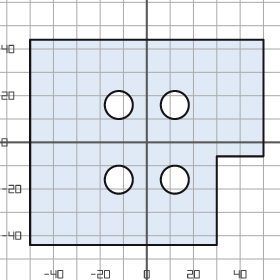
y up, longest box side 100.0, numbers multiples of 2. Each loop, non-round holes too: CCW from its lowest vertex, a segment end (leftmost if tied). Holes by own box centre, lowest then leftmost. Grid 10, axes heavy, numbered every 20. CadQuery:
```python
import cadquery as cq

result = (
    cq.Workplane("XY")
    .moveTo(-50.0, -44.0)
    .lineTo(30.0, -44.0)
    .lineTo(30.0, -6.0)
    .lineTo(50.0, -6.0)
    .lineTo(50.0, 44.0)
    .lineTo(-50.0, 44.0)
    .close()
    .moveTo(-12.0, -16.0)
    .circle(6.0)
    .moveTo(12.0, -16.0)
    .circle(6.0)
    .moveTo(-12.0, 16.0)
    .circle(6.0)
    .moveTo(12.0, 16.0)
    .circle(6.0)
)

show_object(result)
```